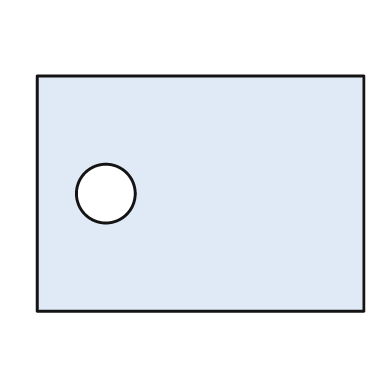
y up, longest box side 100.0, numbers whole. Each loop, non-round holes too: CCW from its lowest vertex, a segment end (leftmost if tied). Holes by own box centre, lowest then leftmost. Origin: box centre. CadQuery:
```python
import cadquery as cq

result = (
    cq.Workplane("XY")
    .moveTo(-50.0, -36.0)
    .lineTo(50.0, -36.0)
    .lineTo(50.0, 36.0)
    .lineTo(-50.0, 36.0)
    .close()
    .moveTo(-29.0, 0.0)
    .circle(9.0)
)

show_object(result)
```